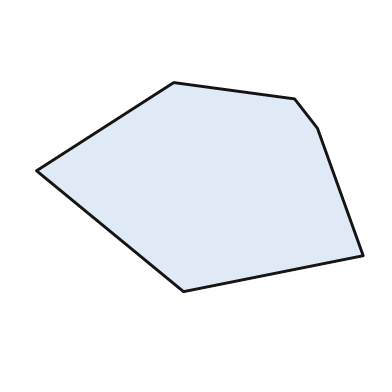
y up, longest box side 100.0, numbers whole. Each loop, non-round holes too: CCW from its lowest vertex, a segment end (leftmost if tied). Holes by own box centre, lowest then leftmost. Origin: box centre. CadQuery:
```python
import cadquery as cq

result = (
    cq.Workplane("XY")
    .moveTo(-5.0, -32.0)
    .lineTo(50.0, -21.0)
    .lineTo(36.0, 18.0)
    .lineTo(29.0, 27.0)
    .lineTo(-8.0, 32.0)
    .lineTo(-50.0, 5.0)
    .close()
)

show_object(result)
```